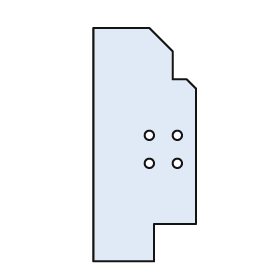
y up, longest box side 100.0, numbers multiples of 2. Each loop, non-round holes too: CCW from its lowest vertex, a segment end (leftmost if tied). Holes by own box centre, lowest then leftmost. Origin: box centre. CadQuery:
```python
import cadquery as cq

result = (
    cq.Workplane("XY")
    .moveTo(-22.0, -50.0)
    .lineTo(4.0, -50.0)
    .lineTo(4.0, -34.0)
    .lineTo(22.0, -34.0)
    .lineTo(22.0, 24.0)
    .lineTo(18.0, 28.0)
    .lineTo(12.0, 28.0)
    .lineTo(12.0, 40.0)
    .lineTo(2.0, 50.0)
    .lineTo(-22.0, 50.0)
    .close()
    .moveTo(2.0, -8.0)
    .circle(2.0)
    .moveTo(14.0, -8.0)
    .circle(2.0)
    .moveTo(2.0, 4.0)
    .circle(2.0)
    .moveTo(14.0, 4.0)
    .circle(2.0)
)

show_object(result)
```